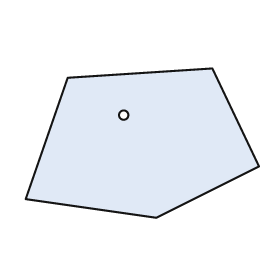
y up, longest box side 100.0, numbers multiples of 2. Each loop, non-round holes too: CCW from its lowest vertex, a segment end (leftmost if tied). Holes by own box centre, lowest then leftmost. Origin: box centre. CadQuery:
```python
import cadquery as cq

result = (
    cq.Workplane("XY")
    .moveTo(6.0, -32.0)
    .lineTo(50.0, -10.0)
    .lineTo(30.0, 32.0)
    .lineTo(-32.0, 28.0)
    .lineTo(-50.0, -24.0)
    .close()
    .moveTo(-8.0, 12.0)
    .circle(2.0)
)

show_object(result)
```